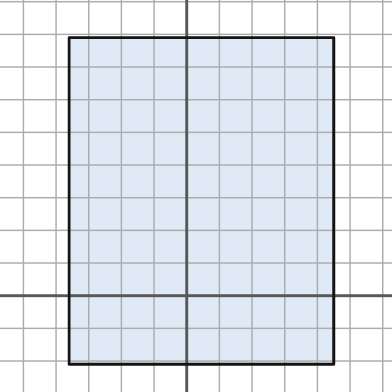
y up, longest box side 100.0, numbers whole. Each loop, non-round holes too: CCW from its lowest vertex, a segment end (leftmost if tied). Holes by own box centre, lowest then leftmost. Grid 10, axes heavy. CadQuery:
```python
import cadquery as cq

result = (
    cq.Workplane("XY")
    .moveTo(-36.0, -21.0)
    .lineTo(45.0, -21.0)
    .lineTo(45.0, 79.0)
    .lineTo(-36.0, 79.0)
    .close()
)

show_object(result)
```